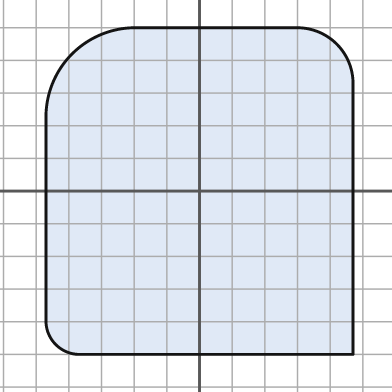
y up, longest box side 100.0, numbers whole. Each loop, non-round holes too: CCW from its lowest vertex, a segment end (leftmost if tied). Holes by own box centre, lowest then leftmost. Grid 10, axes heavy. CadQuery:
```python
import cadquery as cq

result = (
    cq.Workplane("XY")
    .moveTo(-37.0, -50.0)
    .lineTo(47.0, -50.0)
    .lineTo(47.0, 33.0)
    .threePointArc((42.0, 45.0), (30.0, 50.0))
    .lineTo(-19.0, 50.0)
    .threePointArc((-39.0, 42.0), (-47.0, 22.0))
    .lineTo(-47.0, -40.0)
    .threePointArc((-44.0, -47.0), (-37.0, -50.0))
    .close()
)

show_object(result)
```